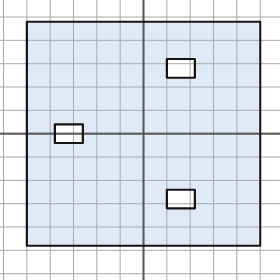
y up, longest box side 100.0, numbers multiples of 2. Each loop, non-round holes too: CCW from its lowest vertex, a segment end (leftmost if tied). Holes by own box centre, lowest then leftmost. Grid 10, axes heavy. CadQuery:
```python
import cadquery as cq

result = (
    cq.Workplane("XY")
    .moveTo(-50.0, -48.0)
    .lineTo(50.0, -48.0)
    .lineTo(50.0, 48.0)
    .lineTo(-50.0, 48.0)
    .close()
    .moveTo(10.0, -32.0)
    .lineTo(22.0, -32.0)
    .lineTo(22.0, -24.0)
    .lineTo(10.0, -24.0)
    .close()
    .moveTo(-38.0, -4.0)
    .lineTo(-26.0, -4.0)
    .lineTo(-26.0, 4.0)
    .lineTo(-38.0, 4.0)
    .close()
    .moveTo(10.0, 24.0)
    .lineTo(22.0, 24.0)
    .lineTo(22.0, 32.0)
    .lineTo(10.0, 32.0)
    .close()
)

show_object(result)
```